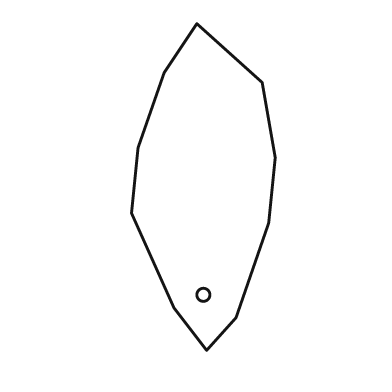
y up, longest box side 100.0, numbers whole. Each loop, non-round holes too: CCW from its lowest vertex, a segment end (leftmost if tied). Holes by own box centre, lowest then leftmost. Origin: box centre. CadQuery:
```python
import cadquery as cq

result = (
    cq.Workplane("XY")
    .moveTo(1.0, -50.0)
    .lineTo(10.0, -40.0)
    .lineTo(20.0, -11.0)
    .lineTo(22.0, 9.0)
    .lineTo(18.0, 32.0)
    .lineTo(-2.0, 50.0)
    .lineTo(-12.0, 35.0)
    .lineTo(-20.0, 12.0)
    .lineTo(-22.0, -8.0)
    .lineTo(-9.0, -37.0)
    .close()
    .moveTo(0.0, -33.0)
    .circle(2.0)
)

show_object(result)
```